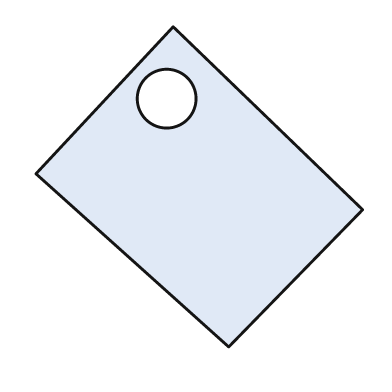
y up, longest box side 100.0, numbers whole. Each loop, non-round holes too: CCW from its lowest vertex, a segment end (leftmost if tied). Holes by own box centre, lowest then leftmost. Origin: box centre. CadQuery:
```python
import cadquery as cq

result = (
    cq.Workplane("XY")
    .moveTo(9.0, -49.0)
    .lineTo(50.0, -7.0)
    .lineTo(-8.0, 49.0)
    .lineTo(-50.0, 4.0)
    .close()
    .moveTo(-10.0, 27.0)
    .circle(9.0)
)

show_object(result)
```